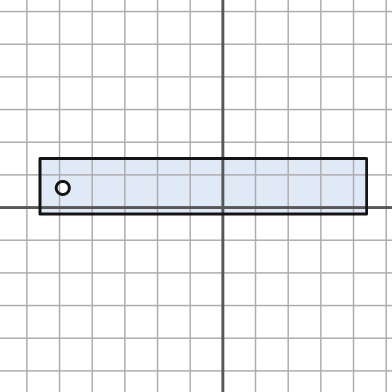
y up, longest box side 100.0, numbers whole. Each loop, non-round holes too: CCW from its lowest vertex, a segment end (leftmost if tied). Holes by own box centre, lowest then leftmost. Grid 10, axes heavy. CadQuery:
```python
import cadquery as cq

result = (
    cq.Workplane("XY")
    .moveTo(-56.0, -2.0)
    .lineTo(44.0, -2.0)
    .lineTo(44.0, 15.0)
    .lineTo(-56.0, 15.0)
    .close()
    .moveTo(-49.0, 6.0)
    .circle(2.0)
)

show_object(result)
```